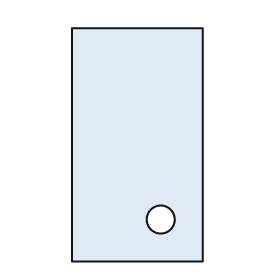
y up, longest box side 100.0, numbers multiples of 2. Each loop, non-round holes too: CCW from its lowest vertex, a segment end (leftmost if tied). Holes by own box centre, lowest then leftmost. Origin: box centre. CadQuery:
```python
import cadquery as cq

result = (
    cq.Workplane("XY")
    .moveTo(-28.0, -50.0)
    .lineTo(28.0, -50.0)
    .lineTo(28.0, 50.0)
    .lineTo(-28.0, 50.0)
    .close()
    .moveTo(10.0, -32.0)
    .circle(6.0)
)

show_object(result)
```